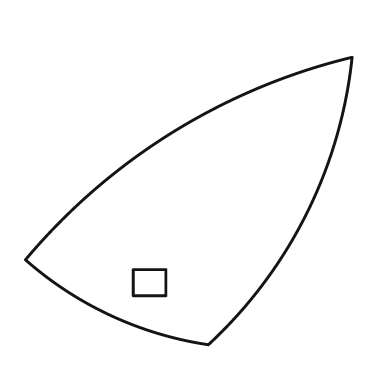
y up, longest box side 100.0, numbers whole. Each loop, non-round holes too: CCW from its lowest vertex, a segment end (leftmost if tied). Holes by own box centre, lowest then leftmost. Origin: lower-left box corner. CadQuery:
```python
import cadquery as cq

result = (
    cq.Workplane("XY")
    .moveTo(56.0, 0.0)
    .threePointArc((86.0, 40.0), (100.0, 88.0))
    .threePointArc((45.0, 65.0), (0.0, 26.0))
    .threePointArc((26.0, 9.0), (56.0, 0.0))
    .close()
    .moveTo(33.0, 15.0)
    .lineTo(43.0, 15.0)
    .lineTo(43.0, 23.0)
    .lineTo(33.0, 23.0)
    .close()
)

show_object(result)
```